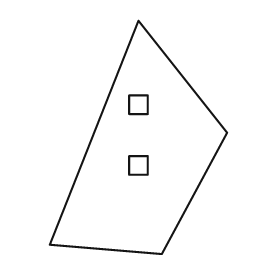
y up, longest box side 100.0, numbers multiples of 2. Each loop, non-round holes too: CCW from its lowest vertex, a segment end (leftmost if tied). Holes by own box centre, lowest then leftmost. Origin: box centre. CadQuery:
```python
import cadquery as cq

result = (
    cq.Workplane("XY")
    .moveTo(10.0, -50.0)
    .lineTo(38.0, 2.0)
    .lineTo(0.0, 50.0)
    .lineTo(-38.0, -46.0)
    .close()
    .moveTo(-4.0, -16.0)
    .lineTo(4.0, -16.0)
    .lineTo(4.0, -8.0)
    .lineTo(-4.0, -8.0)
    .close()
    .moveTo(-4.0, 10.0)
    .lineTo(4.0, 10.0)
    .lineTo(4.0, 18.0)
    .lineTo(-4.0, 18.0)
    .close()
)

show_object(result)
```